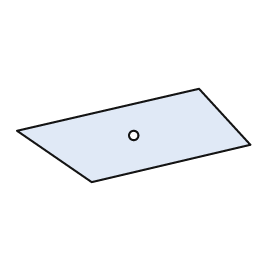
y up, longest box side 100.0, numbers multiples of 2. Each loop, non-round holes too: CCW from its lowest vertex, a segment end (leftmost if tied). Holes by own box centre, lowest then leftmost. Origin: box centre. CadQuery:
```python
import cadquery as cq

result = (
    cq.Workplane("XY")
    .moveTo(-18.0, -20.0)
    .lineTo(50.0, -4.0)
    .lineTo(28.0, 20.0)
    .lineTo(-50.0, 2.0)
    .close()
    .moveTo(0.0, 0.0)
    .circle(2.0)
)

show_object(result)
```